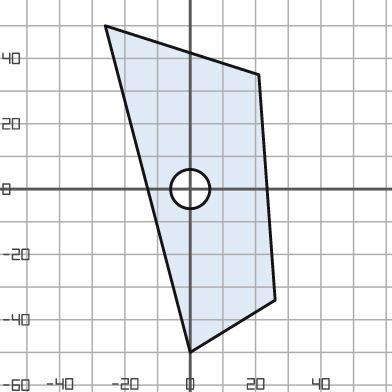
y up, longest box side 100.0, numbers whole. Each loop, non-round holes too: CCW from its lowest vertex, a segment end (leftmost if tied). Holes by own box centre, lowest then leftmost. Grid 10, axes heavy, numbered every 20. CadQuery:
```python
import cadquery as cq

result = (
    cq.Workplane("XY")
    .moveTo(0.0, -50.0)
    .lineTo(26.0, -34.0)
    .lineTo(21.0, 35.0)
    .lineTo(-26.0, 50.0)
    .close()
    .moveTo(0.0, 0.0)
    .circle(6.0)
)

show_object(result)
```